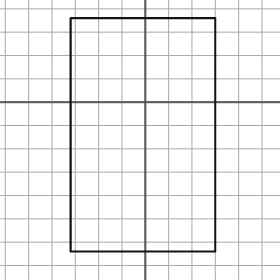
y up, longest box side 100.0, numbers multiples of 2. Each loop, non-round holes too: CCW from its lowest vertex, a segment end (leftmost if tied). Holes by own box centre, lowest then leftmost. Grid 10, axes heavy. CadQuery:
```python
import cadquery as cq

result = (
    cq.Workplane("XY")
    .moveTo(-32.0, -64.0)
    .lineTo(30.0, -64.0)
    .lineTo(30.0, 36.0)
    .lineTo(-32.0, 36.0)
    .close()
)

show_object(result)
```